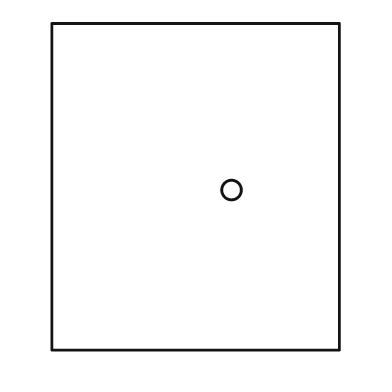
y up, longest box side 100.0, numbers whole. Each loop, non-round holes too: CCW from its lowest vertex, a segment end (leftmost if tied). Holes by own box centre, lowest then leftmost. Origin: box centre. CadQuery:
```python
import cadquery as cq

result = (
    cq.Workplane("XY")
    .moveTo(-44.0, -50.0)
    .lineTo(44.0, -50.0)
    .lineTo(44.0, 50.0)
    .lineTo(-44.0, 50.0)
    .close()
    .moveTo(11.0, -1.0)
    .circle(3.0)
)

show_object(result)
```